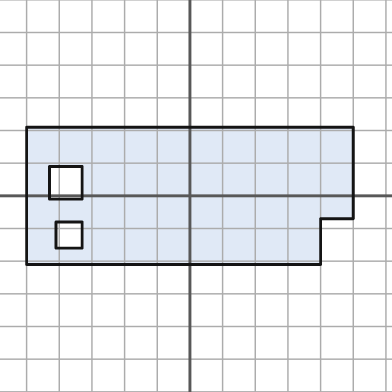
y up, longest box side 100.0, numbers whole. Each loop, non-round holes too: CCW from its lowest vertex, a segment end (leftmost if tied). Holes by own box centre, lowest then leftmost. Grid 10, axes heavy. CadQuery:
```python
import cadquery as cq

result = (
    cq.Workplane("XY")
    .moveTo(-50.0, -21.0)
    .lineTo(40.0, -21.0)
    .lineTo(40.0, -7.0)
    .lineTo(50.0, -7.0)
    .lineTo(50.0, 21.0)
    .lineTo(-50.0, 21.0)
    .close()
    .moveTo(-41.0, -16.0)
    .lineTo(-33.0, -16.0)
    .lineTo(-33.0, -8.0)
    .lineTo(-41.0, -8.0)
    .close()
    .moveTo(-43.0, -1.0)
    .lineTo(-33.0, -1.0)
    .lineTo(-33.0, 9.0)
    .lineTo(-43.0, 9.0)
    .close()
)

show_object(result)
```